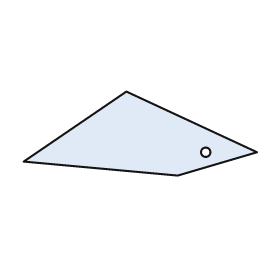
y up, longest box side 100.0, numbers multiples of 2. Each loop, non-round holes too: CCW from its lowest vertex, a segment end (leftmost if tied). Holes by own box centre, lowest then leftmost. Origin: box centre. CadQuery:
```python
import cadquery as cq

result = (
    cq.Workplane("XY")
    .moveTo(16.0, -18.0)
    .lineTo(50.0, -8.0)
    .lineTo(-6.0, 18.0)
    .lineTo(-50.0, -12.0)
    .close()
    .moveTo(28.0, -8.0)
    .circle(2.0)
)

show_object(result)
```